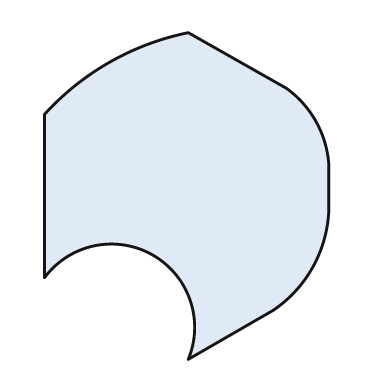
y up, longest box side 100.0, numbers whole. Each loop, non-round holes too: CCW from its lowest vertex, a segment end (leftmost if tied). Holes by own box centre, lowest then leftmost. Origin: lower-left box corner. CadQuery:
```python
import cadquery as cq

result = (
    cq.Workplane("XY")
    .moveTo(44.0, 0.0)
    .lineTo(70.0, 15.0)
    .threePointArc((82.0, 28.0), (87.0, 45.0))
    .lineTo(87.0, 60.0)
    .threePointArc((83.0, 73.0), (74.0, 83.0))
    .lineTo(44.0, 100.0)
    .threePointArc((20.0, 91.0), (0.0, 75.0))
    .lineTo(0.0, 25.0)
    .threePointArc((33.0, 32.0), (44.0, 0.0))
    .close()
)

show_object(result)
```